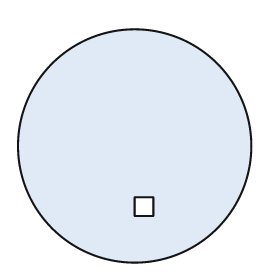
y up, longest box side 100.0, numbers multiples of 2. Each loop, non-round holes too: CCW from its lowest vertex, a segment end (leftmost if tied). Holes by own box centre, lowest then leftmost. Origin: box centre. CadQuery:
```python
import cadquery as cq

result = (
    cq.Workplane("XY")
    .moveTo(0.0, 0.0)
    .circle(50.0)
    .moveTo(0.0, -30.0)
    .lineTo(8.0, -30.0)
    .lineTo(8.0, -22.0)
    .lineTo(0.0, -22.0)
    .close()
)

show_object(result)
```